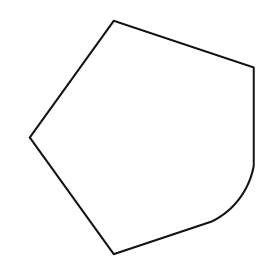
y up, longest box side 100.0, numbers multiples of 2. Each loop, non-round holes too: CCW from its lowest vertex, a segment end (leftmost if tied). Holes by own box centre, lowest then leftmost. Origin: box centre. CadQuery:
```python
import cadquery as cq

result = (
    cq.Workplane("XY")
    .moveTo(-12.0, -50.0)
    .lineTo(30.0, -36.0)
    .threePointArc((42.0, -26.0), (48.0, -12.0))
    .lineTo(48.0, 30.0)
    .lineTo(-12.0, 50.0)
    .lineTo(-48.0, 0.0)
    .close()
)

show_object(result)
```